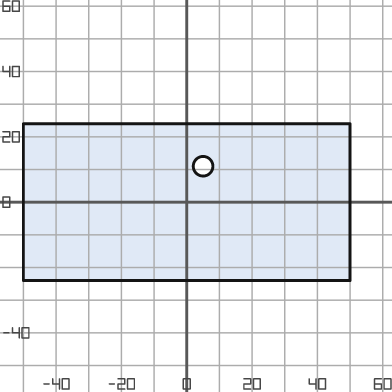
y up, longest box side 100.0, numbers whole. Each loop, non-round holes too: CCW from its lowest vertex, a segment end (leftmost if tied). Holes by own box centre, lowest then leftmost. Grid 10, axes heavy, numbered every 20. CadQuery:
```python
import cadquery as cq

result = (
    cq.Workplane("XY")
    .moveTo(-50.0, -24.0)
    .lineTo(50.0, -24.0)
    .lineTo(50.0, 24.0)
    .lineTo(-50.0, 24.0)
    .close()
    .moveTo(5.0, 11.0)
    .circle(3.0)
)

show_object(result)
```